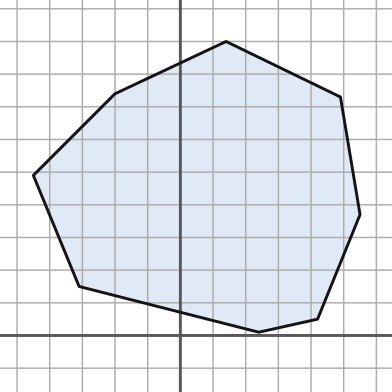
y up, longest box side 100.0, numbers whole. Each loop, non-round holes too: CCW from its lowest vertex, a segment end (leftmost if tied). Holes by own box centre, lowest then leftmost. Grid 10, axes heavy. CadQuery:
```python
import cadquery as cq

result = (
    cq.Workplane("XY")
    .moveTo(24.0, 1.0)
    .lineTo(42.0, 5.0)
    .lineTo(55.0, 37.0)
    .lineTo(49.0, 73.0)
    .lineTo(14.0, 90.0)
    .lineTo(-20.0, 74.0)
    .lineTo(-45.0, 49.0)
    .lineTo(-31.0, 15.0)
    .close()
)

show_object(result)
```